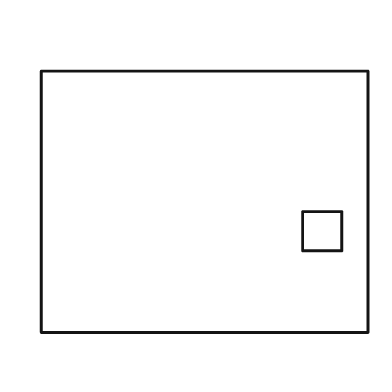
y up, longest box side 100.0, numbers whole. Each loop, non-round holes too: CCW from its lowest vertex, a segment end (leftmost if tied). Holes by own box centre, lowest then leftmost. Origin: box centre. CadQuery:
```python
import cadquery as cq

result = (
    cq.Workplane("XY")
    .moveTo(-50.0, -40.0)
    .lineTo(50.0, -40.0)
    .lineTo(50.0, 40.0)
    .lineTo(-50.0, 40.0)
    .close()
    .moveTo(30.0, -15.0)
    .lineTo(42.0, -15.0)
    .lineTo(42.0, -3.0)
    .lineTo(30.0, -3.0)
    .close()
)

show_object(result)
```